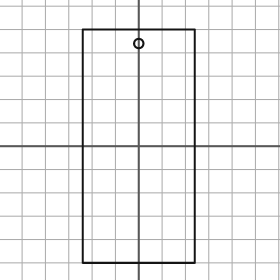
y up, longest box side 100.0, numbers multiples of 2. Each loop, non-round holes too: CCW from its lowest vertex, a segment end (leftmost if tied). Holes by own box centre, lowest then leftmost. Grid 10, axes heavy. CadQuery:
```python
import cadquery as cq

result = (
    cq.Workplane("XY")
    .moveTo(-24.0, -50.0)
    .lineTo(24.0, -50.0)
    .lineTo(24.0, 50.0)
    .lineTo(-24.0, 50.0)
    .close()
    .moveTo(0.0, 44.0)
    .circle(2.0)
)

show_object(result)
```